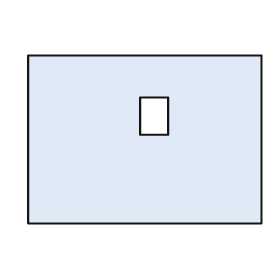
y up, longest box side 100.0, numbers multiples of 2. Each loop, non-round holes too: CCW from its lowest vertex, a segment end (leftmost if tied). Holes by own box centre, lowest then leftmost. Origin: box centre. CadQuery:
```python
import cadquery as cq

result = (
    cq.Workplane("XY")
    .moveTo(-50.0, -36.0)
    .lineTo(50.0, -36.0)
    .lineTo(50.0, 36.0)
    .lineTo(-50.0, 36.0)
    .close()
    .moveTo(-2.0, 2.0)
    .lineTo(10.0, 2.0)
    .lineTo(10.0, 18.0)
    .lineTo(-2.0, 18.0)
    .close()
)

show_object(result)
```